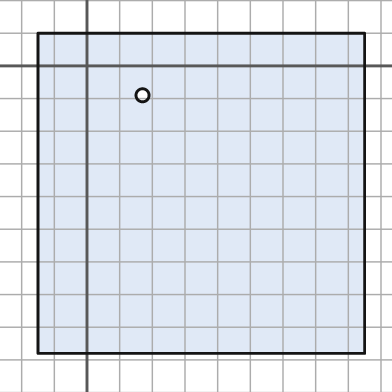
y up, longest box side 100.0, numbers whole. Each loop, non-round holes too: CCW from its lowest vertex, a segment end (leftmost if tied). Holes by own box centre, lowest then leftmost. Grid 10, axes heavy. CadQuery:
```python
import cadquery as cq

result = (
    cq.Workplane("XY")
    .moveTo(-15.0, -88.0)
    .lineTo(85.0, -88.0)
    .lineTo(85.0, 10.0)
    .lineTo(-15.0, 10.0)
    .close()
    .moveTo(17.0, -9.0)
    .circle(2.0)
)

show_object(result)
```